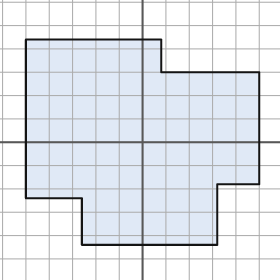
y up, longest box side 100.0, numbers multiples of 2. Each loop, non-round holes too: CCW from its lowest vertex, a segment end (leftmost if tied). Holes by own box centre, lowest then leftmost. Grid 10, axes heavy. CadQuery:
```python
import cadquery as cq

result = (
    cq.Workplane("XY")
    .moveTo(-26.0, -44.0)
    .lineTo(32.0, -44.0)
    .lineTo(32.0, -18.0)
    .lineTo(50.0, -18.0)
    .lineTo(50.0, 30.0)
    .lineTo(8.0, 30.0)
    .lineTo(8.0, 44.0)
    .lineTo(-50.0, 44.0)
    .lineTo(-50.0, -24.0)
    .lineTo(-26.0, -24.0)
    .close()
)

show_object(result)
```